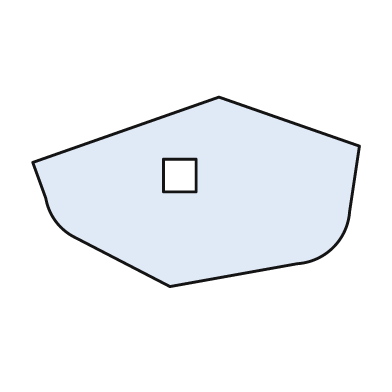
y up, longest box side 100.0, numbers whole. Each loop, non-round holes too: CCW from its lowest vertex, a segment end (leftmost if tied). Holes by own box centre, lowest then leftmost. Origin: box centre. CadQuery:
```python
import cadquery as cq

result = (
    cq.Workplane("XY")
    .moveTo(-8.0, -29.0)
    .lineTo(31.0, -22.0)
    .threePointArc((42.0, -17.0), (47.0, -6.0))
    .lineTo(50.0, 14.0)
    .lineTo(7.0, 29.0)
    .lineTo(-50.0, 9.0)
    .lineTo(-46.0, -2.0)
    .threePointArc((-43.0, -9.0), (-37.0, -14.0))
    .close()
    .moveTo(-10.0, 0.0)
    .lineTo(0.0, 0.0)
    .lineTo(0.0, 10.0)
    .lineTo(-10.0, 10.0)
    .close()
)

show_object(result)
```